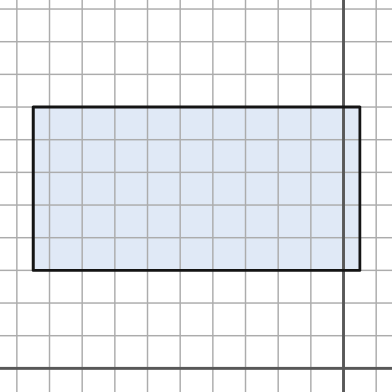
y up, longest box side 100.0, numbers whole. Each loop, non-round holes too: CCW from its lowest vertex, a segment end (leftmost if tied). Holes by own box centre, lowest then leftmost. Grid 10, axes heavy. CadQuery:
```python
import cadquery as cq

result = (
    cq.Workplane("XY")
    .moveTo(-95.0, 30.0)
    .lineTo(5.0, 30.0)
    .lineTo(5.0, 80.0)
    .lineTo(-95.0, 80.0)
    .close()
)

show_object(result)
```